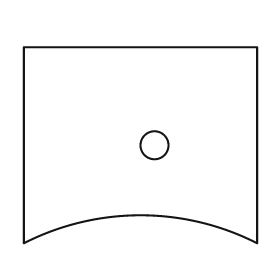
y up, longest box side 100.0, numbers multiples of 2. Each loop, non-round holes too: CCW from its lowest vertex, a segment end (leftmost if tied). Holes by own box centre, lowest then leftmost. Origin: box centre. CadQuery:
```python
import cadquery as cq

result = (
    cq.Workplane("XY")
    .moveTo(-50.0, -42.0)
    .threePointArc((0.0, -30.0), (50.0, -42.0))
    .lineTo(50.0, 42.0)
    .lineTo(-50.0, 42.0)
    .close()
    .moveTo(6.0, 0.0)
    .circle(6.0)
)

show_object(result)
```